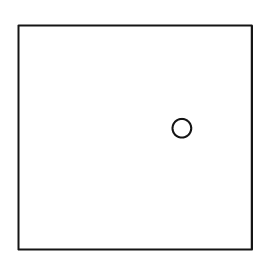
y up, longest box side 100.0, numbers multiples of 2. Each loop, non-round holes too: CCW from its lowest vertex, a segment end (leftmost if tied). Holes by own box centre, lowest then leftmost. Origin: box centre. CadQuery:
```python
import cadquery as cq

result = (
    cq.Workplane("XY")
    .moveTo(-50.0, -48.0)
    .lineTo(50.0, -48.0)
    .lineTo(50.0, 48.0)
    .lineTo(-50.0, 48.0)
    .close()
    .moveTo(20.0, 4.0)
    .circle(4.0)
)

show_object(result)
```